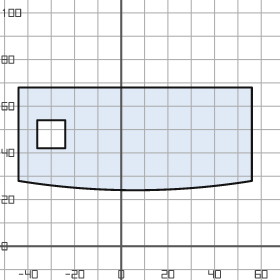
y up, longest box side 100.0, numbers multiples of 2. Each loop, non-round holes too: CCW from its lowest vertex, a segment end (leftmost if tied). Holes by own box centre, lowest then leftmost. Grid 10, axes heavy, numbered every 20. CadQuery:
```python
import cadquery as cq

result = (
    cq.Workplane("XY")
    .moveTo(-44.0, 28.0)
    .threePointArc((6.0, 24.0), (56.0, 28.0))
    .lineTo(56.0, 68.0)
    .lineTo(-44.0, 68.0)
    .close()
    .moveTo(-36.0, 42.0)
    .lineTo(-24.0, 42.0)
    .lineTo(-24.0, 54.0)
    .lineTo(-36.0, 54.0)
    .close()
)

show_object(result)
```